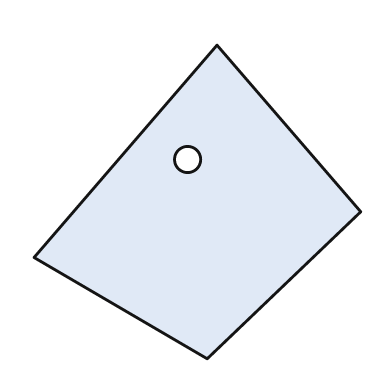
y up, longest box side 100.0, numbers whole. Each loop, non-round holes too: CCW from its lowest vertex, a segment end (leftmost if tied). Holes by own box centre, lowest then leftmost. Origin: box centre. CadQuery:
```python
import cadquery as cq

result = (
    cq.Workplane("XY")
    .moveTo(3.0, -48.0)
    .lineTo(50.0, -3.0)
    .lineTo(6.0, 48.0)
    .lineTo(-50.0, -17.0)
    .close()
    .moveTo(-3.0, 13.0)
    .circle(4.0)
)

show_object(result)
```